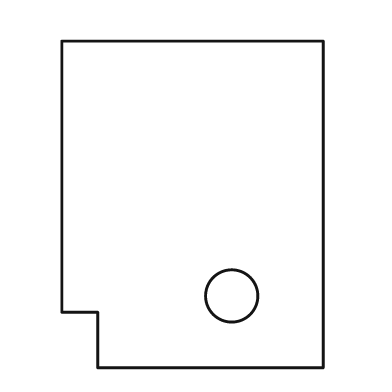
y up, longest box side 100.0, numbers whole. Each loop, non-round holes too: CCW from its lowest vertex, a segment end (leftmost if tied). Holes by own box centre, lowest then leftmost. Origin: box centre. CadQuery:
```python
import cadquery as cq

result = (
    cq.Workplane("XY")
    .moveTo(-29.0, -50.0)
    .lineTo(40.0, -50.0)
    .lineTo(40.0, 50.0)
    .lineTo(-40.0, 50.0)
    .lineTo(-40.0, -33.0)
    .lineTo(-29.0, -33.0)
    .close()
    .moveTo(12.0, -28.0)
    .circle(8.0)
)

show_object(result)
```